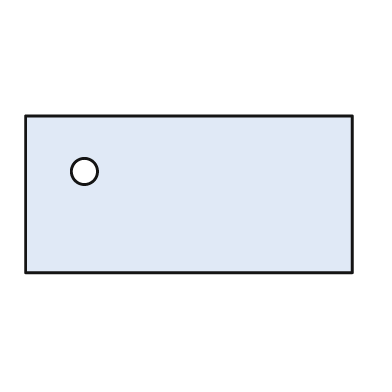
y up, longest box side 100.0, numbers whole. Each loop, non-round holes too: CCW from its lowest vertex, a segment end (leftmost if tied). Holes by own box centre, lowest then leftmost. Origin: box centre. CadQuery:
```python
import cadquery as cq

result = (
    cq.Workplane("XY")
    .moveTo(-50.0, -24.0)
    .lineTo(50.0, -24.0)
    .lineTo(50.0, 24.0)
    .lineTo(-50.0, 24.0)
    .close()
    .moveTo(-32.0, 7.0)
    .circle(4.0)
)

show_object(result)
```